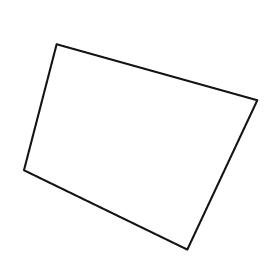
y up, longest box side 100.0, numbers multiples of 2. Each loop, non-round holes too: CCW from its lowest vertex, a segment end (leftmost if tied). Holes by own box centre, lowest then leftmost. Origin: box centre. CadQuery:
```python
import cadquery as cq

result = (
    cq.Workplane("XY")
    .moveTo(20.0, -44.0)
    .lineTo(50.0, 20.0)
    .lineTo(-36.0, 44.0)
    .lineTo(-50.0, -10.0)
    .close()
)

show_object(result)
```